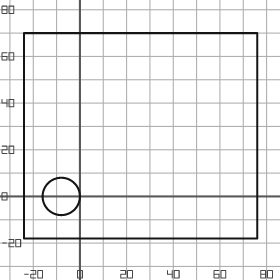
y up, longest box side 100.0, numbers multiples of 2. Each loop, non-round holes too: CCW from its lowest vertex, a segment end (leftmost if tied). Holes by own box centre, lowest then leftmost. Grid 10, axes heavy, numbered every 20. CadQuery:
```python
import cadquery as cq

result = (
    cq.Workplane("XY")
    .moveTo(-24.0, -18.0)
    .lineTo(76.0, -18.0)
    .lineTo(76.0, 70.0)
    .lineTo(-24.0, 70.0)
    .close()
    .moveTo(-8.0, 0.0)
    .circle(8.0)
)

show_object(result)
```